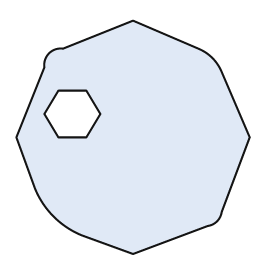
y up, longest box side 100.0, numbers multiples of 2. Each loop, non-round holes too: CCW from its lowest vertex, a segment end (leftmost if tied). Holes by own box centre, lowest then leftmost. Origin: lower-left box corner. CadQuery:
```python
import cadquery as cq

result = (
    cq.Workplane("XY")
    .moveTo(50.0, 0.0)
    .lineTo(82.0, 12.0)
    .threePointArc((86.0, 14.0), (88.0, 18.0))
    .lineTo(100.0, 50.0)
    .lineTo(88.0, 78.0)
    .threePointArc((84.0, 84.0), (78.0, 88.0))
    .lineTo(50.0, 100.0)
    .lineTo(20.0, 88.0)
    .threePointArc((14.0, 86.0), (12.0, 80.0))
    .lineTo(0.0, 50.0)
    .lineTo(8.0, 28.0)
    .threePointArc((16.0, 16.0), (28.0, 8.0))
    .close()
    .moveTo(18.0, 50.0)
    .lineTo(30.0, 50.0)
    .lineTo(36.0, 60.0)
    .lineTo(30.0, 70.0)
    .lineTo(18.0, 70.0)
    .lineTo(12.0, 60.0)
    .close()
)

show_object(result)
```